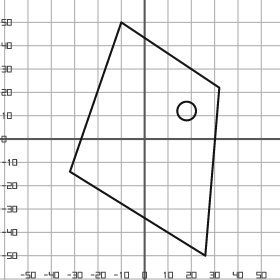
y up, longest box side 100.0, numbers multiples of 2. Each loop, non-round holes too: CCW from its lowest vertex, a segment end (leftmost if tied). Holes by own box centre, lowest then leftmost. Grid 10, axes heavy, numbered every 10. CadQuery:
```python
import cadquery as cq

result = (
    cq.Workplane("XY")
    .moveTo(26.0, -50.0)
    .lineTo(32.0, 22.0)
    .lineTo(-10.0, 50.0)
    .lineTo(-32.0, -14.0)
    .close()
    .moveTo(18.0, 12.0)
    .circle(4.0)
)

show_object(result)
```